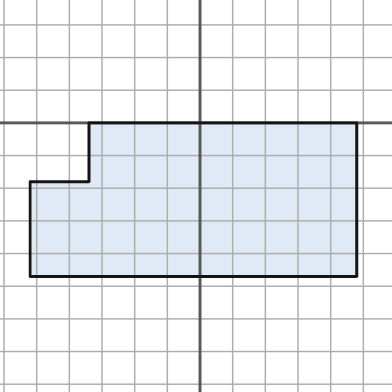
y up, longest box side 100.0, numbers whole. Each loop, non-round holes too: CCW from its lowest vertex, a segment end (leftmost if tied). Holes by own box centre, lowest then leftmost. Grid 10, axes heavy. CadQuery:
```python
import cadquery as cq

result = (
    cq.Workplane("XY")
    .moveTo(-52.0, -47.0)
    .lineTo(48.0, -47.0)
    .lineTo(48.0, 0.0)
    .lineTo(-34.0, 0.0)
    .lineTo(-34.0, -18.0)
    .lineTo(-52.0, -18.0)
    .close()
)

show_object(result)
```